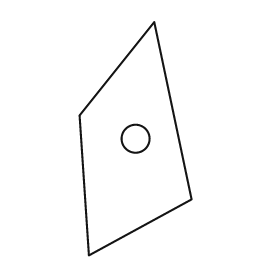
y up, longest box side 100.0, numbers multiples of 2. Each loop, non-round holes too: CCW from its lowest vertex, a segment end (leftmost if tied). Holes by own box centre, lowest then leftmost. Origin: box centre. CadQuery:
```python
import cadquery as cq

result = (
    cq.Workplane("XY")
    .moveTo(-20.0, -50.0)
    .lineTo(24.0, -26.0)
    .lineTo(8.0, 50.0)
    .lineTo(-24.0, 10.0)
    .close()
    .moveTo(0.0, 0.0)
    .circle(6.0)
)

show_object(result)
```